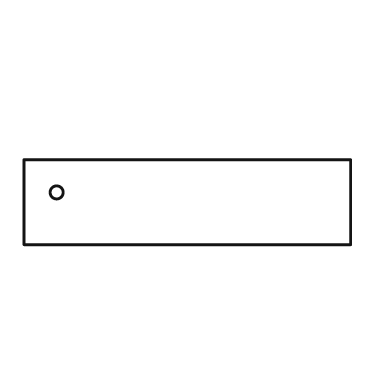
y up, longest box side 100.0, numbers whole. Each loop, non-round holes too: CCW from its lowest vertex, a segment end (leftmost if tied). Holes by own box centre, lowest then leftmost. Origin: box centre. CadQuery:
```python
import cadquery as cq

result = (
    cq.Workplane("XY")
    .moveTo(-50.0, -13.0)
    .lineTo(50.0, -13.0)
    .lineTo(50.0, 13.0)
    .lineTo(-50.0, 13.0)
    .close()
    .moveTo(-40.0, 3.0)
    .circle(2.0)
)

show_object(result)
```